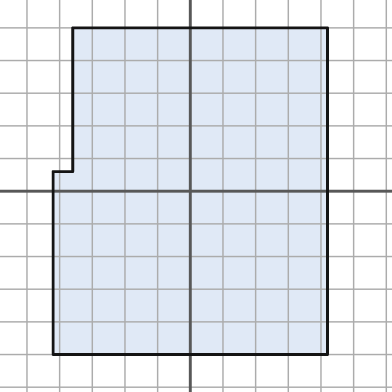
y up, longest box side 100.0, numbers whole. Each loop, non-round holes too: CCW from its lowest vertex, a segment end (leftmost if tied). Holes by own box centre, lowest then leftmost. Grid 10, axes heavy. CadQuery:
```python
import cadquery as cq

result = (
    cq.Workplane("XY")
    .moveTo(-42.0, -50.0)
    .lineTo(42.0, -50.0)
    .lineTo(42.0, 50.0)
    .lineTo(-36.0, 50.0)
    .lineTo(-36.0, 6.0)
    .lineTo(-42.0, 6.0)
    .close()
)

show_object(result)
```